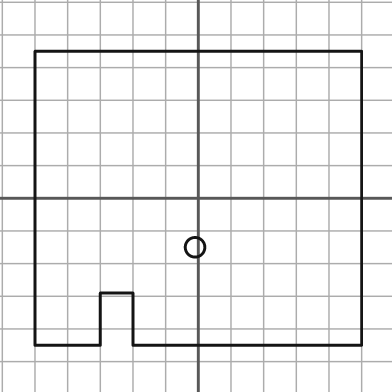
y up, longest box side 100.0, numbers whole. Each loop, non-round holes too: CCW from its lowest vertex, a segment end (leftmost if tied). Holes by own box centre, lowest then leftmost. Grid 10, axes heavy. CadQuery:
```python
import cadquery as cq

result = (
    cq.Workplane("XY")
    .moveTo(-50.0, -45.0)
    .lineTo(-30.0, -45.0)
    .lineTo(-30.0, -29.0)
    .lineTo(-20.0, -29.0)
    .lineTo(-20.0, -45.0)
    .lineTo(50.0, -45.0)
    .lineTo(50.0, 45.0)
    .lineTo(-50.0, 45.0)
    .close()
    .moveTo(-1.0, -15.0)
    .circle(3.0)
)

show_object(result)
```